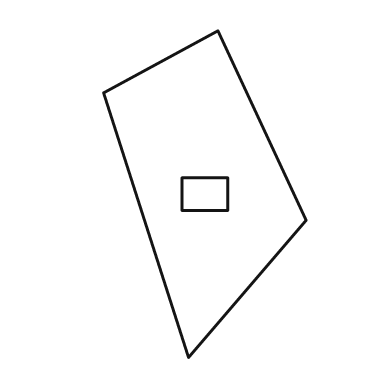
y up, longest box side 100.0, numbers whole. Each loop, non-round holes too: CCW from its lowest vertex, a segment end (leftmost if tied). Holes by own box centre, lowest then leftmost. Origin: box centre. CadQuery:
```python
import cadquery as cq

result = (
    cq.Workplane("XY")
    .moveTo(-5.0, -50.0)
    .lineTo(31.0, -8.0)
    .lineTo(4.0, 50.0)
    .lineTo(-31.0, 31.0)
    .close()
    .moveTo(-7.0, -5.0)
    .lineTo(7.0, -5.0)
    .lineTo(7.0, 5.0)
    .lineTo(-7.0, 5.0)
    .close()
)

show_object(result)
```